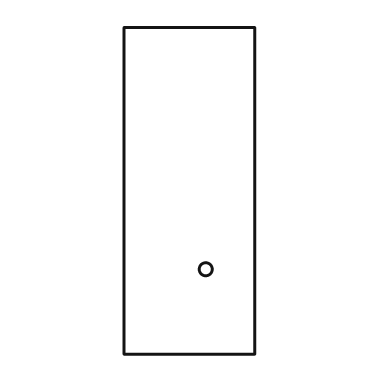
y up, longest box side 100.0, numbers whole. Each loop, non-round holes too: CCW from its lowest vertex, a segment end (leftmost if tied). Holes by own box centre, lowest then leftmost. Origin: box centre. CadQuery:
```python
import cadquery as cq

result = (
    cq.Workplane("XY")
    .moveTo(-20.0, -50.0)
    .lineTo(20.0, -50.0)
    .lineTo(20.0, 50.0)
    .lineTo(-20.0, 50.0)
    .close()
    .moveTo(5.0, -24.0)
    .circle(2.0)
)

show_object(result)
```